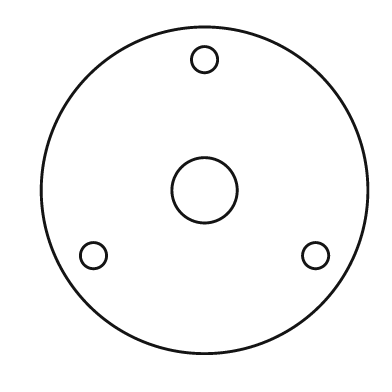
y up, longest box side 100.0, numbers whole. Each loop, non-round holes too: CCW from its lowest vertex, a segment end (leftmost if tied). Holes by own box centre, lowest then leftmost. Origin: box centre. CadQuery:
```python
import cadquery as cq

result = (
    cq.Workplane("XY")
    .moveTo(0.0, 0.0)
    .circle(50.0)
    .moveTo(-34.0, -20.0)
    .circle(4.0)
    .moveTo(34.0, -20.0)
    .circle(4.0)
    .moveTo(0.0, 0.0)
    .circle(10.0)
    .moveTo(0.0, 40.0)
    .circle(4.0)
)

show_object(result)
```